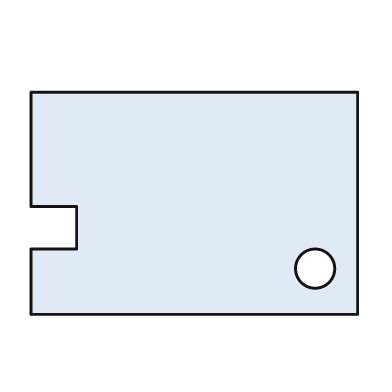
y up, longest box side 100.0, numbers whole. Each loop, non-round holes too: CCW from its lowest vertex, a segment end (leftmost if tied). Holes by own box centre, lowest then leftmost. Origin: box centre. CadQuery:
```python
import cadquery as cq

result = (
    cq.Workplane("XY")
    .moveTo(-50.0, -34.0)
    .lineTo(50.0, -34.0)
    .lineTo(50.0, 34.0)
    .lineTo(-50.0, 34.0)
    .lineTo(-50.0, -1.0)
    .lineTo(-36.0, -1.0)
    .lineTo(-36.0, -14.0)
    .lineTo(-50.0, -14.0)
    .close()
    .moveTo(37.0, -20.0)
    .circle(6.0)
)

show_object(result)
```